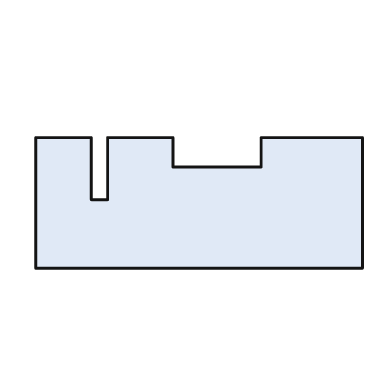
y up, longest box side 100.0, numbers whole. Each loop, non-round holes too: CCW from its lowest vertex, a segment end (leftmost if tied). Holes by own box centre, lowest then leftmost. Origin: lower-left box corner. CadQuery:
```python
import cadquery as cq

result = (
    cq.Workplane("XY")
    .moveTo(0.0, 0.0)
    .lineTo(100.0, 0.0)
    .lineTo(100.0, 40.0)
    .lineTo(69.0, 40.0)
    .lineTo(69.0, 31.0)
    .lineTo(42.0, 31.0)
    .lineTo(42.0, 40.0)
    .lineTo(22.0, 40.0)
    .lineTo(22.0, 21.0)
    .lineTo(17.0, 21.0)
    .lineTo(17.0, 40.0)
    .lineTo(0.0, 40.0)
    .close()
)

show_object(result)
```